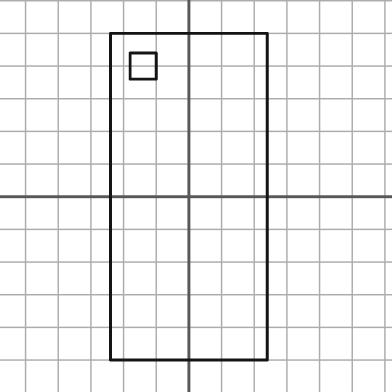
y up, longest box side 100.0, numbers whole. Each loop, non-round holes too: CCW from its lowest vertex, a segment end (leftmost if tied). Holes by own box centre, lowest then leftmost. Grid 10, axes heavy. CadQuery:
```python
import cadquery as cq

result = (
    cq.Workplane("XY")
    .moveTo(-24.0, -50.0)
    .lineTo(24.0, -50.0)
    .lineTo(24.0, 50.0)
    .lineTo(-24.0, 50.0)
    .close()
    .moveTo(-18.0, 36.0)
    .lineTo(-10.0, 36.0)
    .lineTo(-10.0, 44.0)
    .lineTo(-18.0, 44.0)
    .close()
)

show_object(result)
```